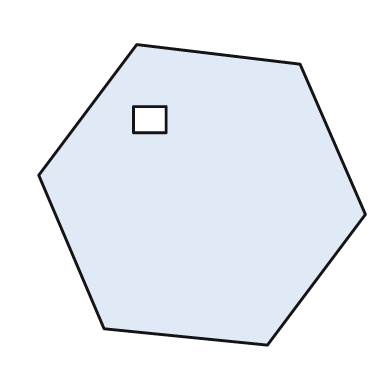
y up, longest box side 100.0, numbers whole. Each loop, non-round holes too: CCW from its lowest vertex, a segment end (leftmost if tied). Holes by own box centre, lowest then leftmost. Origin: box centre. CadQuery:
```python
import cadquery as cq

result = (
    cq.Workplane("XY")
    .moveTo(20.0, -46.0)
    .lineTo(50.0, -6.0)
    .lineTo(30.0, 40.0)
    .lineTo(-20.0, 46.0)
    .lineTo(-50.0, 6.0)
    .lineTo(-30.0, -41.0)
    .close()
    .moveTo(-21.0, 19.0)
    .lineTo(-11.0, 19.0)
    .lineTo(-11.0, 27.0)
    .lineTo(-21.0, 27.0)
    .close()
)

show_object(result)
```